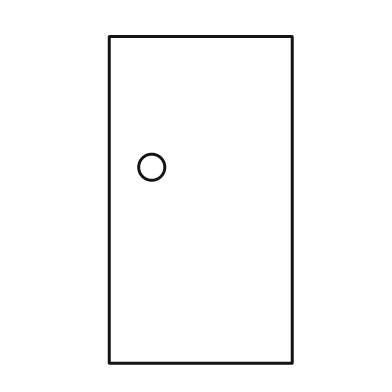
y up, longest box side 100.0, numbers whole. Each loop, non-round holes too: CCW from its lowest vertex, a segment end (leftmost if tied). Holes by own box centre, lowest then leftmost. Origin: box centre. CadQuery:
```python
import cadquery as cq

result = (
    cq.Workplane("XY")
    .moveTo(-28.0, -50.0)
    .lineTo(28.0, -50.0)
    .lineTo(28.0, 50.0)
    .lineTo(-28.0, 50.0)
    .close()
    .moveTo(-15.0, 10.0)
    .circle(4.0)
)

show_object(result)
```